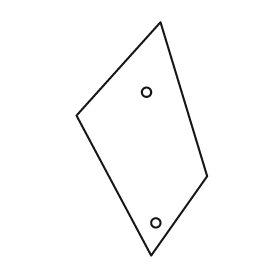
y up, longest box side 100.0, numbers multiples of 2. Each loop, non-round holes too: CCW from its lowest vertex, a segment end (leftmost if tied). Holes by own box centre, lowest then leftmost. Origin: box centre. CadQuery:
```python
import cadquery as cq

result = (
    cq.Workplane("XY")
    .moveTo(4.0, -50.0)
    .lineTo(28.0, -16.0)
    .lineTo(8.0, 50.0)
    .lineTo(-28.0, 10.0)
    .close()
    .moveTo(6.0, -36.0)
    .circle(2.0)
    .moveTo(2.0, 20.0)
    .circle(2.0)
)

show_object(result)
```